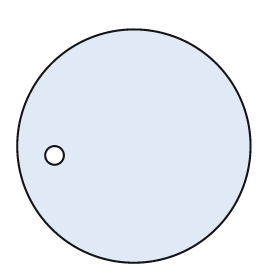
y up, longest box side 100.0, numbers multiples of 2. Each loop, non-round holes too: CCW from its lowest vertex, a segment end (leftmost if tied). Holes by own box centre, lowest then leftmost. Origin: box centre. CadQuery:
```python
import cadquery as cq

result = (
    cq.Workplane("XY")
    .moveTo(0.0, 0.0)
    .circle(50.0)
    .moveTo(-34.0, -4.0)
    .circle(4.0)
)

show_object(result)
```